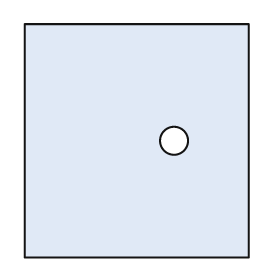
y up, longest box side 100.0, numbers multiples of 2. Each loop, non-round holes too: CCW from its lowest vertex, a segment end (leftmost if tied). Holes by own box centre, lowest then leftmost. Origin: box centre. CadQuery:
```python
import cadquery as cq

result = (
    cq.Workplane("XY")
    .moveTo(-48.0, -50.0)
    .lineTo(48.0, -50.0)
    .lineTo(48.0, 50.0)
    .lineTo(-48.0, 50.0)
    .close()
    .moveTo(16.0, 0.0)
    .circle(6.0)
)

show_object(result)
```